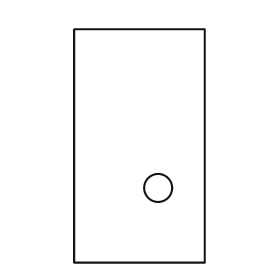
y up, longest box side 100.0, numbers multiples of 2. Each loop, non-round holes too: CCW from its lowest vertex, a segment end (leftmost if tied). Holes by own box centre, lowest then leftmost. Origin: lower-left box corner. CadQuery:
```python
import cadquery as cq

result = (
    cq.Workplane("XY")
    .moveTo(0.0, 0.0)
    .lineTo(56.0, 0.0)
    .lineTo(56.0, 100.0)
    .lineTo(0.0, 100.0)
    .close()
    .moveTo(36.0, 32.0)
    .circle(6.0)
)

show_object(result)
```